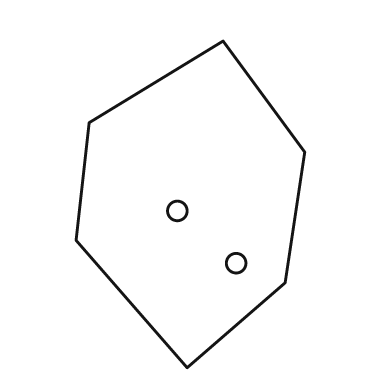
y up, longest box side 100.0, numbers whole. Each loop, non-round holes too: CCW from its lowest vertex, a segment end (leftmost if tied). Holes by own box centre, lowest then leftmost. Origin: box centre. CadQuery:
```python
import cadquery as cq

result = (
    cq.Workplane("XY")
    .moveTo(-1.0, -50.0)
    .lineTo(29.0, -24.0)
    .lineTo(35.0, 16.0)
    .lineTo(10.0, 50.0)
    .lineTo(-31.0, 25.0)
    .lineTo(-35.0, -11.0)
    .close()
    .moveTo(14.0, -18.0)
    .circle(3.0)
    .moveTo(-4.0, -2.0)
    .circle(3.0)
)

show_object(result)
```